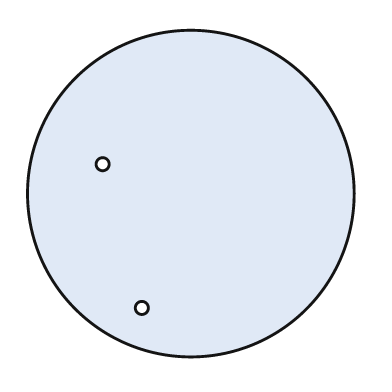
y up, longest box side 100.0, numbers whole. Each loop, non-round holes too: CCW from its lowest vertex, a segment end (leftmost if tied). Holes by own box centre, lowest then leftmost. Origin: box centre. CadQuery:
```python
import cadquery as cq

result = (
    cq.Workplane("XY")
    .moveTo(0.0, 0.0)
    .circle(50.0)
    .moveTo(-15.0, -35.0)
    .circle(2.0)
    .moveTo(-27.0, 9.0)
    .circle(2.0)
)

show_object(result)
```